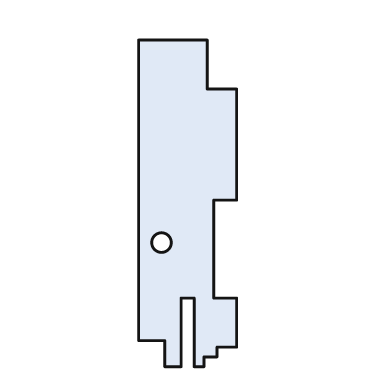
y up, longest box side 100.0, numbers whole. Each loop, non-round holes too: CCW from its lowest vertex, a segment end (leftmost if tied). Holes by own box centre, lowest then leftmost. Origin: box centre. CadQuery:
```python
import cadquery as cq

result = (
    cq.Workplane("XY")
    .moveTo(-7.0, -50.0)
    .lineTo(-2.0, -50.0)
    .lineTo(-2.0, -29.0)
    .lineTo(2.0, -29.0)
    .lineTo(2.0, -50.0)
    .lineTo(5.0, -50.0)
    .lineTo(5.0, -47.0)
    .lineTo(9.0, -47.0)
    .lineTo(9.0, -44.0)
    .lineTo(15.0, -44.0)
    .lineTo(15.0, -29.0)
    .lineTo(8.0, -29.0)
    .lineTo(8.0, 1.0)
    .lineTo(15.0, 1.0)
    .lineTo(15.0, 35.0)
    .lineTo(6.0, 35.0)
    .lineTo(6.0, 50.0)
    .lineTo(-15.0, 50.0)
    .lineTo(-15.0, -42.0)
    .lineTo(-7.0, -42.0)
    .close()
    .moveTo(-8.0, -12.0)
    .circle(3.0)
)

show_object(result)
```